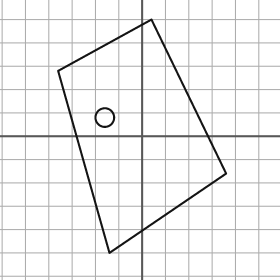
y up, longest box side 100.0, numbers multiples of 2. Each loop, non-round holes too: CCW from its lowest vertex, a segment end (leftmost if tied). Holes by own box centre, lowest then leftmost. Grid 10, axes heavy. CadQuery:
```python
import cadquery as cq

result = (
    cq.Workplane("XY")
    .moveTo(-14.0, -50.0)
    .lineTo(36.0, -16.0)
    .lineTo(4.0, 50.0)
    .lineTo(-36.0, 28.0)
    .close()
    .moveTo(-16.0, 8.0)
    .circle(4.0)
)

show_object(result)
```